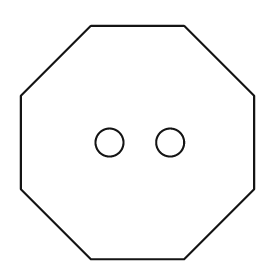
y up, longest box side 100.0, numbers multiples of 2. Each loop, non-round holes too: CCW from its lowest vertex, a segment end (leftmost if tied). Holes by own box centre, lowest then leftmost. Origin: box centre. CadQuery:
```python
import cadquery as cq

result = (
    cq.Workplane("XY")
    .moveTo(-20.0, -50.0)
    .lineTo(20.0, -50.0)
    .lineTo(50.0, -20.0)
    .lineTo(50.0, 20.0)
    .lineTo(20.0, 50.0)
    .lineTo(-20.0, 50.0)
    .lineTo(-50.0, 20.0)
    .lineTo(-50.0, -20.0)
    .close()
    .moveTo(-12.0, 0.0)
    .circle(6.0)
    .moveTo(14.0, 0.0)
    .circle(6.0)
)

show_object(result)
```